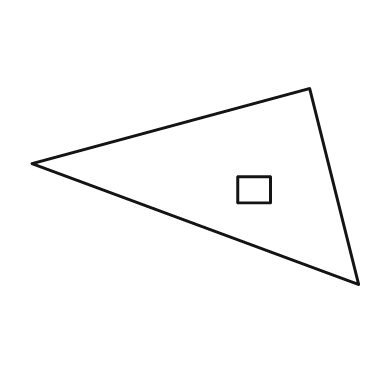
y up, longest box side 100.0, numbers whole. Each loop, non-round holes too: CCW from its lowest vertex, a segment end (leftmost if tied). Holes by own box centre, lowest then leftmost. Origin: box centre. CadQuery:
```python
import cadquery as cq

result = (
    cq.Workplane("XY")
    .moveTo(50.0, -30.0)
    .lineTo(35.0, 30.0)
    .lineTo(-50.0, 7.0)
    .close()
    .moveTo(13.0, -5.0)
    .lineTo(23.0, -5.0)
    .lineTo(23.0, 3.0)
    .lineTo(13.0, 3.0)
    .close()
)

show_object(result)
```